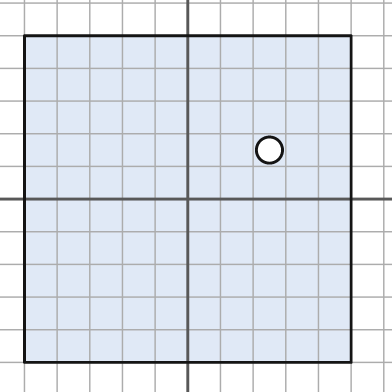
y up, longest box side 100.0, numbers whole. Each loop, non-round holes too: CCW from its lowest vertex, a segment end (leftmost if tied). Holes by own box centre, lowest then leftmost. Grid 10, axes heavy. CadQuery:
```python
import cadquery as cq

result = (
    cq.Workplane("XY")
    .moveTo(-50.0, -50.0)
    .lineTo(50.0, -50.0)
    .lineTo(50.0, 50.0)
    .lineTo(-50.0, 50.0)
    .close()
    .moveTo(25.0, 15.0)
    .circle(4.0)
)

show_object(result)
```